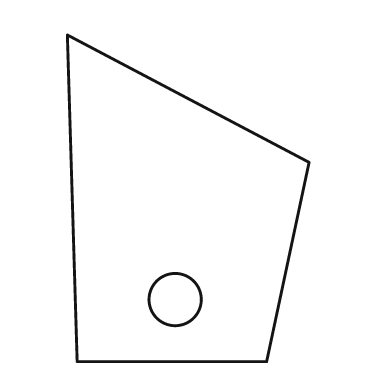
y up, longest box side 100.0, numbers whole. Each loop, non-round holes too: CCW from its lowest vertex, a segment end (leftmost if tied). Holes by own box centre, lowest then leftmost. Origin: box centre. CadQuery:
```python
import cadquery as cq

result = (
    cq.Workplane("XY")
    .moveTo(-34.0, -50.0)
    .lineTo(24.0, -50.0)
    .lineTo(37.0, 11.0)
    .lineTo(-37.0, 50.0)
    .close()
    .moveTo(-4.0, -31.0)
    .circle(8.0)
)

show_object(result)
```